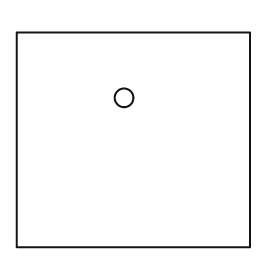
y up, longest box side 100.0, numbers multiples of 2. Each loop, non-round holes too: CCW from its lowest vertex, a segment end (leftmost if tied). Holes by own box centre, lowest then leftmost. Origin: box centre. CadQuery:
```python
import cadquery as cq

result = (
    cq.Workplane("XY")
    .moveTo(-50.0, -46.0)
    .lineTo(50.0, -46.0)
    .lineTo(50.0, 46.0)
    .lineTo(-50.0, 46.0)
    .close()
    .moveTo(-4.0, 18.0)
    .circle(4.0)
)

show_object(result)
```